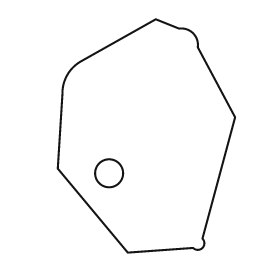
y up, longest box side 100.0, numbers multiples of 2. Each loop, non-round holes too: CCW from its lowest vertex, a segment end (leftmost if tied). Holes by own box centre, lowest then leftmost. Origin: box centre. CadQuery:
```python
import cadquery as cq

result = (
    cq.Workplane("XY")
    .moveTo(-8.0, -50.0)
    .lineTo(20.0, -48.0)
    .threePointArc((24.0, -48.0), (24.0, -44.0))
    .lineTo(38.0, 8.0)
    .lineTo(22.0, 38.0)
    .threePointArc((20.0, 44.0), (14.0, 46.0))
    .lineTo(4.0, 50.0)
    .lineTo(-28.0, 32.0)
    .threePointArc((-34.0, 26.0), (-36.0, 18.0))
    .lineTo(-38.0, -14.0)
    .close()
    .moveTo(-16.0, -16.0)
    .circle(6.0)
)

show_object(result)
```